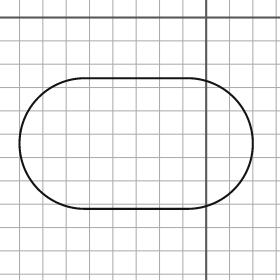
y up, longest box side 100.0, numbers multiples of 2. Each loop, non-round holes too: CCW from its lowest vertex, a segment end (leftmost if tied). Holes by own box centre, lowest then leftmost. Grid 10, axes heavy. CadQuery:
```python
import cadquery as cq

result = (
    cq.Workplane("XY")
    .moveTo(-52.0, -82.0)
    .lineTo(-8.0, -82.0)
    .threePointArc((20.0, -54.0), (-8.0, -26.0))
    .lineTo(-52.0, -26.0)
    .threePointArc((-80.0, -54.0), (-52.0, -82.0))
    .close()
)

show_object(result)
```